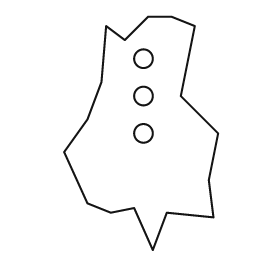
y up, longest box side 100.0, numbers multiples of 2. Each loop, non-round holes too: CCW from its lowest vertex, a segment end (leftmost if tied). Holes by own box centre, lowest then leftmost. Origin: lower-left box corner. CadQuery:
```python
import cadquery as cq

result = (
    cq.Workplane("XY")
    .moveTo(38.0, 0.0)
    .lineTo(44.0, 16.0)
    .lineTo(64.0, 14.0)
    .lineTo(62.0, 30.0)
    .lineTo(66.0, 50.0)
    .lineTo(50.0, 66.0)
    .lineTo(56.0, 96.0)
    .lineTo(46.0, 100.0)
    .lineTo(36.0, 100.0)
    .lineTo(26.0, 90.0)
    .lineTo(18.0, 96.0)
    .lineTo(16.0, 72.0)
    .lineTo(10.0, 56.0)
    .lineTo(0.0, 42.0)
    .lineTo(10.0, 20.0)
    .lineTo(20.0, 16.0)
    .lineTo(30.0, 18.0)
    .close()
    .moveTo(34.0, 50.0)
    .circle(4.0)
    .moveTo(34.0, 66.0)
    .circle(4.0)
    .moveTo(34.0, 82.0)
    .circle(4.0)
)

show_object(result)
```